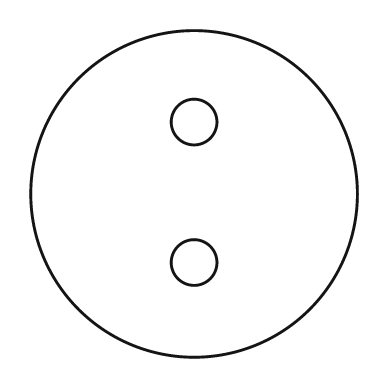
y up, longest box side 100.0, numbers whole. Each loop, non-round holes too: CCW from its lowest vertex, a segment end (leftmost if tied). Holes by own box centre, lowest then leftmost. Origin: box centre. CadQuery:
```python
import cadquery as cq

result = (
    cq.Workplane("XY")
    .moveTo(0.0, 0.0)
    .circle(50.0)
    .moveTo(0.0, -21.0)
    .circle(7.0)
    .moveTo(0.0, 22.0)
    .circle(7.0)
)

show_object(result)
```